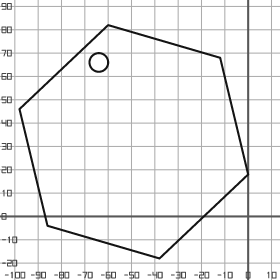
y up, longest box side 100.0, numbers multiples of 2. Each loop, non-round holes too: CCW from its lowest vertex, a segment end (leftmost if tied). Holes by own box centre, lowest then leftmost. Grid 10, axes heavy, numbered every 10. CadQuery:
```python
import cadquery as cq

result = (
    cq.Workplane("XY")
    .moveTo(-38.0, -18.0)
    .lineTo(0.0, 18.0)
    .lineTo(-12.0, 68.0)
    .lineTo(-60.0, 82.0)
    .lineTo(-98.0, 46.0)
    .lineTo(-86.0, -4.0)
    .close()
    .moveTo(-64.0, 66.0)
    .circle(4.0)
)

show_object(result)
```